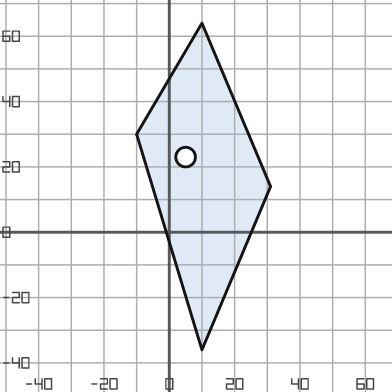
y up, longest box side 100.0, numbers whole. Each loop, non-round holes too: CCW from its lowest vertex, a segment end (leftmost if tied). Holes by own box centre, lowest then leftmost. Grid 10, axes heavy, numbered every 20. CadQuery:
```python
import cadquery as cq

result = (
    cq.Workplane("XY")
    .moveTo(10.0, -36.0)
    .lineTo(31.0, 14.0)
    .lineTo(10.0, 64.0)
    .lineTo(-10.0, 30.0)
    .close()
    .moveTo(5.0, 23.0)
    .circle(3.0)
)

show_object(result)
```